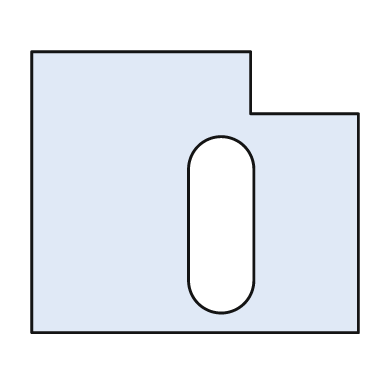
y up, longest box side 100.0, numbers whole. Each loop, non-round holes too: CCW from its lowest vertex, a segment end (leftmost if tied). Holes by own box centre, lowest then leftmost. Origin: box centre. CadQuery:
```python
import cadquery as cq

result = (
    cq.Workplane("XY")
    .moveTo(-50.0, -43.0)
    .lineTo(50.0, -43.0)
    .lineTo(50.0, 24.0)
    .lineTo(17.0, 24.0)
    .lineTo(17.0, 43.0)
    .lineTo(-50.0, 43.0)
    .close()
    .moveTo(-2.0, -27.0)
    .threePointArc((8.0, -37.0), (18.0, -27.0))
    .lineTo(18.0, 7.0)
    .threePointArc((8.0, 17.0), (-2.0, 7.0))
    .close()
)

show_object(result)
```